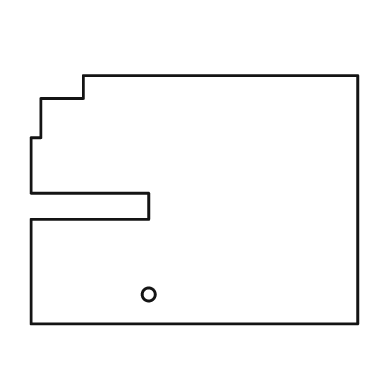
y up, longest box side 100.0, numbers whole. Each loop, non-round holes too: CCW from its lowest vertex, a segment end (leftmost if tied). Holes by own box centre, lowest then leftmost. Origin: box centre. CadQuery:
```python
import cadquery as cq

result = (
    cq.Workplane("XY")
    .moveTo(-50.0, -38.0)
    .lineTo(50.0, -38.0)
    .lineTo(50.0, 38.0)
    .lineTo(-34.0, 38.0)
    .lineTo(-34.0, 31.0)
    .lineTo(-47.0, 31.0)
    .lineTo(-47.0, 19.0)
    .lineTo(-50.0, 19.0)
    .lineTo(-50.0, 2.0)
    .lineTo(-14.0, 2.0)
    .lineTo(-14.0, -6.0)
    .lineTo(-50.0, -6.0)
    .close()
    .moveTo(-14.0, -29.0)
    .circle(2.0)
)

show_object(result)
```